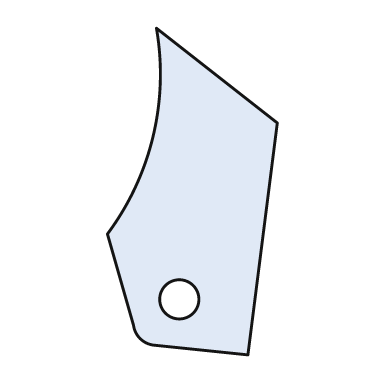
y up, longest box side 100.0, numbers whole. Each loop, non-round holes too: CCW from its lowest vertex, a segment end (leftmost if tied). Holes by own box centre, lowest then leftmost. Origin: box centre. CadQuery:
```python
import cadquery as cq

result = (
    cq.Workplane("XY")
    .moveTo(17.0, -50.0)
    .lineTo(26.0, 21.0)
    .lineTo(-11.0, 50.0)
    .threePointArc((-12.0, 17.0), (-26.0, -13.0))
    .lineTo(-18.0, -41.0)
    .threePointArc((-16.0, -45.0), (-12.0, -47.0))
    .close()
    .moveTo(-4.0, -33.0)
    .circle(6.0)
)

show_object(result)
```